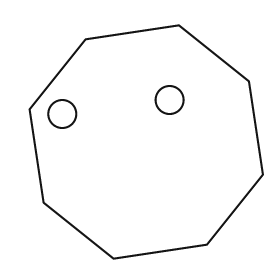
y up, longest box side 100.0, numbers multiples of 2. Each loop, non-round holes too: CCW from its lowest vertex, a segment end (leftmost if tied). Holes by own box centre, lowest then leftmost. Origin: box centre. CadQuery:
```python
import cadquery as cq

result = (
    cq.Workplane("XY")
    .moveTo(-14.0, -50.0)
    .lineTo(26.0, -44.0)
    .lineTo(50.0, -14.0)
    .lineTo(44.0, 26.0)
    .lineTo(14.0, 50.0)
    .lineTo(-26.0, 44.0)
    .lineTo(-50.0, 14.0)
    .lineTo(-44.0, -26.0)
    .close()
    .moveTo(-36.0, 12.0)
    .circle(6.0)
    .moveTo(10.0, 18.0)
    .circle(6.0)
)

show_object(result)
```